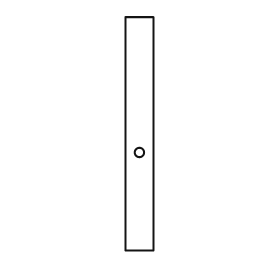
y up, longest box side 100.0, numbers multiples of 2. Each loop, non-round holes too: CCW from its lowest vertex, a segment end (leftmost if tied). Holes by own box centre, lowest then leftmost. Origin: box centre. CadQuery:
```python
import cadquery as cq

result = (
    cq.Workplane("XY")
    .moveTo(-6.0, -50.0)
    .lineTo(6.0, -50.0)
    .lineTo(6.0, 50.0)
    .lineTo(-6.0, 50.0)
    .close()
    .moveTo(0.0, -8.0)
    .circle(2.0)
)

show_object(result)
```